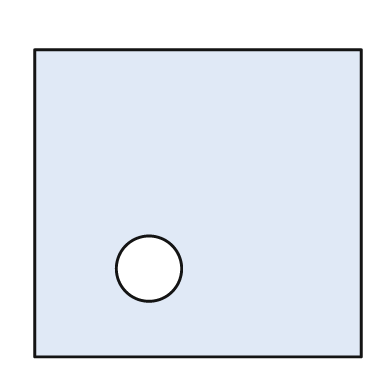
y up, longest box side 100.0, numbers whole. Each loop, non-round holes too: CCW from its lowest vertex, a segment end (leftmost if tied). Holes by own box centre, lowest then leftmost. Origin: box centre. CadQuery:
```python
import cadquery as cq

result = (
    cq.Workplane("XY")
    .moveTo(-50.0, -47.0)
    .lineTo(50.0, -47.0)
    .lineTo(50.0, 47.0)
    .lineTo(-50.0, 47.0)
    .close()
    .moveTo(-15.0, -20.0)
    .circle(10.0)
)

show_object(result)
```